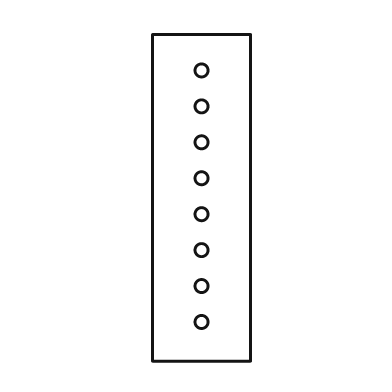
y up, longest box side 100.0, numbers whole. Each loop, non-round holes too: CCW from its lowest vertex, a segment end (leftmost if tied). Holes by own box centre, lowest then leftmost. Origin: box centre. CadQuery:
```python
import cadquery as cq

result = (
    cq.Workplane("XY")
    .moveTo(-15.0, -50.0)
    .lineTo(15.0, -50.0)
    .lineTo(15.0, 50.0)
    .lineTo(-15.0, 50.0)
    .close()
    .moveTo(0.0, -38.0)
    .circle(2.0)
    .moveTo(0.0, -27.0)
    .circle(2.0)
    .moveTo(0.0, -16.0)
    .circle(2.0)
    .moveTo(0.0, -5.0)
    .circle(2.0)
    .moveTo(0.0, 6.0)
    .circle(2.0)
    .moveTo(0.0, 17.0)
    .circle(2.0)
    .moveTo(0.0, 28.0)
    .circle(2.0)
    .moveTo(0.0, 39.0)
    .circle(2.0)
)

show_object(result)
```